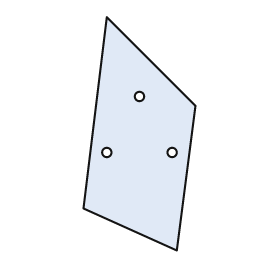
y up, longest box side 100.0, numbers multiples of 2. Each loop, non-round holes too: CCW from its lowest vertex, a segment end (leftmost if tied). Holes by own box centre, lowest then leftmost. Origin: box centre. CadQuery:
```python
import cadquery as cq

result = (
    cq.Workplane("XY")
    .moveTo(16.0, -50.0)
    .lineTo(24.0, 12.0)
    .lineTo(-14.0, 50.0)
    .lineTo(-24.0, -32.0)
    .close()
    .moveTo(-14.0, -8.0)
    .circle(2.0)
    .moveTo(14.0, -8.0)
    .circle(2.0)
    .moveTo(0.0, 16.0)
    .circle(2.0)
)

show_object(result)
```